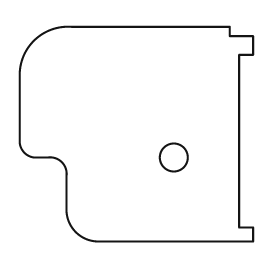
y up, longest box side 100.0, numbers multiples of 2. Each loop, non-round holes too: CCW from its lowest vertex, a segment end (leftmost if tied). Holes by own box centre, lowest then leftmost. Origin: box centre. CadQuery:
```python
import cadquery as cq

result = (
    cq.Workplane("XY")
    .moveTo(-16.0, -46.0)
    .lineTo(50.0, -46.0)
    .lineTo(50.0, -40.0)
    .lineTo(44.0, -40.0)
    .lineTo(44.0, 34.0)
    .lineTo(50.0, 34.0)
    .lineTo(50.0, 42.0)
    .lineTo(40.0, 42.0)
    .lineTo(40.0, 46.0)
    .lineTo(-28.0, 46.0)
    .threePointArc((-44.0, 40.0), (-50.0, 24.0))
    .lineTo(-50.0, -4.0)
    .threePointArc((-48.0, -8.0), (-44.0, -10.0))
    .lineTo(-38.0, -10.0)
    .threePointArc((-32.0, -12.0), (-30.0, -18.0))
    .lineTo(-30.0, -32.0)
    .threePointArc((-26.0, -42.0), (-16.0, -46.0))
    .close()
    .moveTo(16.0, -10.0)
    .circle(6.0)
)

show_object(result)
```